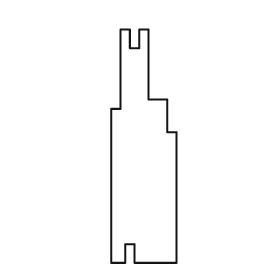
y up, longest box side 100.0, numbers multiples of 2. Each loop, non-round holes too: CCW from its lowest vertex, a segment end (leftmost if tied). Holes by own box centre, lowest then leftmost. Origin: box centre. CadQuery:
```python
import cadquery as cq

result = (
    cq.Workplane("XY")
    .moveTo(-14.0, -50.0)
    .lineTo(-8.0, -50.0)
    .lineTo(-8.0, -42.0)
    .lineTo(-4.0, -42.0)
    .lineTo(-4.0, -50.0)
    .lineTo(14.0, -50.0)
    .lineTo(14.0, 6.0)
    .lineTo(10.0, 6.0)
    .lineTo(10.0, 20.0)
    .lineTo(2.0, 20.0)
    .lineTo(2.0, 50.0)
    .lineTo(-2.0, 50.0)
    .lineTo(-2.0, 42.0)
    .lineTo(-6.0, 42.0)
    .lineTo(-6.0, 50.0)
    .lineTo(-10.0, 50.0)
    .lineTo(-10.0, 16.0)
    .lineTo(-14.0, 16.0)
    .close()
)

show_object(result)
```